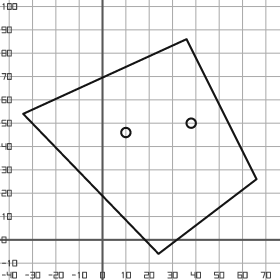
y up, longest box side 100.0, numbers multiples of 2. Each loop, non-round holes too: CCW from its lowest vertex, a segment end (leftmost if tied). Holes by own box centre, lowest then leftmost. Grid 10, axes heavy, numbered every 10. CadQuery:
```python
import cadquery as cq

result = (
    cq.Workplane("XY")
    .moveTo(24.0, -6.0)
    .lineTo(66.0, 26.0)
    .lineTo(36.0, 86.0)
    .lineTo(-34.0, 54.0)
    .close()
    .moveTo(10.0, 46.0)
    .circle(2.0)
    .moveTo(38.0, 50.0)
    .circle(2.0)
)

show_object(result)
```